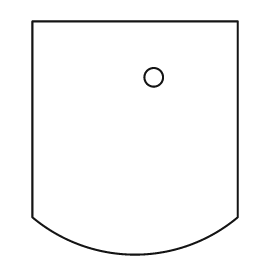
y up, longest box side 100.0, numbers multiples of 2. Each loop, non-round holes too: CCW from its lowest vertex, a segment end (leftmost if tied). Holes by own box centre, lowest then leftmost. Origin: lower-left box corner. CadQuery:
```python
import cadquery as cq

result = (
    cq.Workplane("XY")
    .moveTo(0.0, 16.0)
    .threePointArc((44.0, 0.0), (88.0, 16.0))
    .lineTo(88.0, 100.0)
    .lineTo(0.0, 100.0)
    .close()
    .moveTo(52.0, 76.0)
    .circle(4.0)
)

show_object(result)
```